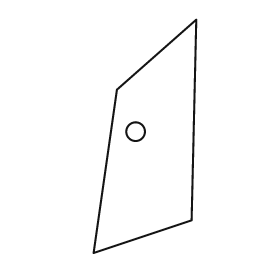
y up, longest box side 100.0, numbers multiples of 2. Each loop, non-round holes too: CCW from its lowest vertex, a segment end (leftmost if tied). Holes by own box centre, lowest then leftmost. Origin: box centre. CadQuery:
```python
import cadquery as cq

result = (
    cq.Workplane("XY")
    .moveTo(-22.0, -50.0)
    .lineTo(20.0, -36.0)
    .lineTo(22.0, 50.0)
    .lineTo(-12.0, 20.0)
    .close()
    .moveTo(-4.0, 2.0)
    .circle(4.0)
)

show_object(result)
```